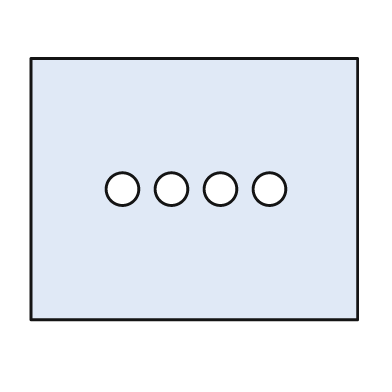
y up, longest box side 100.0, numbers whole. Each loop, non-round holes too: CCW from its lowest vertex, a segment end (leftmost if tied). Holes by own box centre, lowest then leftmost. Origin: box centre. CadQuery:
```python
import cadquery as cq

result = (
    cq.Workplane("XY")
    .moveTo(-50.0, -40.0)
    .lineTo(50.0, -40.0)
    .lineTo(50.0, 40.0)
    .lineTo(-50.0, 40.0)
    .close()
    .moveTo(-22.0, 0.0)
    .circle(5.0)
    .moveTo(-7.0, 0.0)
    .circle(5.0)
    .moveTo(8.0, 0.0)
    .circle(5.0)
    .moveTo(23.0, 0.0)
    .circle(5.0)
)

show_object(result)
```